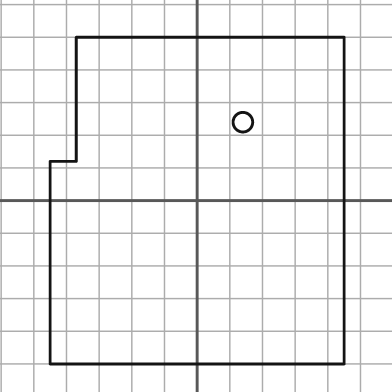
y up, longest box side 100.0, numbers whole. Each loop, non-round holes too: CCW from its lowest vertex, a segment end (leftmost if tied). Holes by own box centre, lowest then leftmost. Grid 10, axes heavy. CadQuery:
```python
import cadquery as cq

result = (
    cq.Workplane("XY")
    .moveTo(-45.0, -50.0)
    .lineTo(45.0, -50.0)
    .lineTo(45.0, 50.0)
    .lineTo(-37.0, 50.0)
    .lineTo(-37.0, 12.0)
    .lineTo(-45.0, 12.0)
    .close()
    .moveTo(14.0, 24.0)
    .circle(3.0)
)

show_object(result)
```